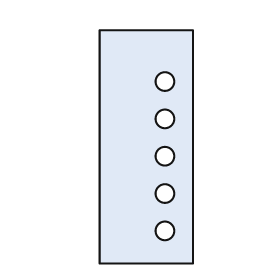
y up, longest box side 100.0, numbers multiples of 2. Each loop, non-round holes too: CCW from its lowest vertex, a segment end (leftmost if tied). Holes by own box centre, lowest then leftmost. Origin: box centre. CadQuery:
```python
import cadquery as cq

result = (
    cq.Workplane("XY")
    .moveTo(-20.0, -50.0)
    .lineTo(20.0, -50.0)
    .lineTo(20.0, 50.0)
    .lineTo(-20.0, 50.0)
    .close()
    .moveTo(8.0, -36.0)
    .circle(4.0)
    .moveTo(8.0, -20.0)
    .circle(4.0)
    .moveTo(8.0, -4.0)
    .circle(4.0)
    .moveTo(8.0, 12.0)
    .circle(4.0)
    .moveTo(8.0, 28.0)
    .circle(4.0)
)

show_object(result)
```